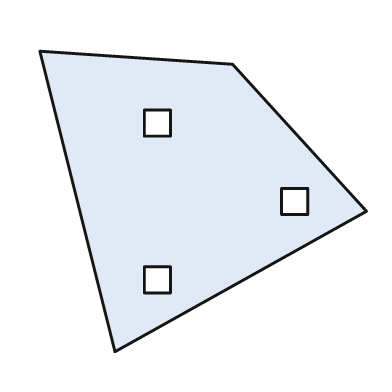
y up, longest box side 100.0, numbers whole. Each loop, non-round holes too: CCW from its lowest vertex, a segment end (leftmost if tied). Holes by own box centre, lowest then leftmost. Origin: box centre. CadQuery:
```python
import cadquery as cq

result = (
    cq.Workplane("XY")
    .moveTo(-27.0, -46.0)
    .lineTo(50.0, -3.0)
    .lineTo(9.0, 42.0)
    .lineTo(-50.0, 46.0)
    .close()
    .moveTo(-18.0, -28.0)
    .lineTo(-10.0, -28.0)
    .lineTo(-10.0, -20.0)
    .lineTo(-18.0, -20.0)
    .close()
    .moveTo(24.0, -4.0)
    .lineTo(32.0, -4.0)
    .lineTo(32.0, 4.0)
    .lineTo(24.0, 4.0)
    .close()
    .moveTo(-18.0, 20.0)
    .lineTo(-10.0, 20.0)
    .lineTo(-10.0, 28.0)
    .lineTo(-18.0, 28.0)
    .close()
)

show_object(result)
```